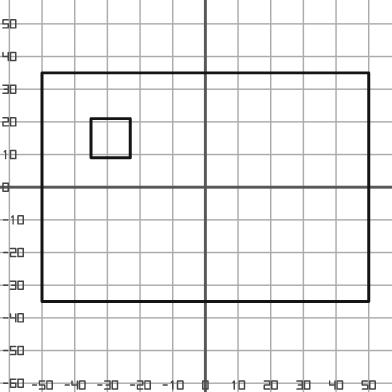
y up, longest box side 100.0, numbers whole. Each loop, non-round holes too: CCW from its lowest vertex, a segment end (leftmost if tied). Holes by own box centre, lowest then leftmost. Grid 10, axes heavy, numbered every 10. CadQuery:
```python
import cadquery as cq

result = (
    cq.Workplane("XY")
    .moveTo(-50.0, -35.0)
    .lineTo(50.0, -35.0)
    .lineTo(50.0, 35.0)
    .lineTo(-50.0, 35.0)
    .close()
    .moveTo(-35.0, 9.0)
    .lineTo(-23.0, 9.0)
    .lineTo(-23.0, 21.0)
    .lineTo(-35.0, 21.0)
    .close()
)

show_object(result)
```